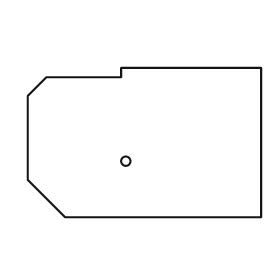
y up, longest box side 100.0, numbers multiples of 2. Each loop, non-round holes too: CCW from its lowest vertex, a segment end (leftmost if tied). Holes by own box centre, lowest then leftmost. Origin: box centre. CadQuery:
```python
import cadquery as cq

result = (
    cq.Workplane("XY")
    .moveTo(-34.0, -32.0)
    .lineTo(50.0, -32.0)
    .lineTo(50.0, 32.0)
    .lineTo(-10.0, 32.0)
    .lineTo(-10.0, 28.0)
    .lineTo(-42.0, 28.0)
    .lineTo(-50.0, 20.0)
    .lineTo(-50.0, -16.0)
    .close()
    .moveTo(-8.0, -8.0)
    .circle(2.0)
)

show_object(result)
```